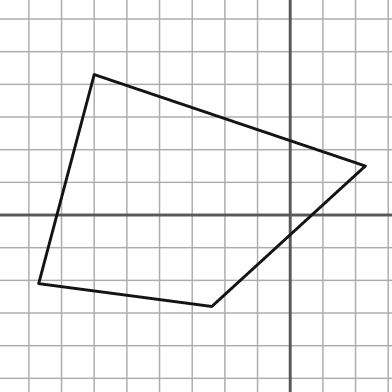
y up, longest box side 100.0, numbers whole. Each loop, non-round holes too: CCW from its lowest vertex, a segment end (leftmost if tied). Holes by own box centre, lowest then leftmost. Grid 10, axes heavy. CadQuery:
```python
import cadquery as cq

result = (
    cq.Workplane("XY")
    .moveTo(-24.0, -28.0)
    .lineTo(23.0, 15.0)
    .lineTo(-60.0, 43.0)
    .lineTo(-77.0, -21.0)
    .close()
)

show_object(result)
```